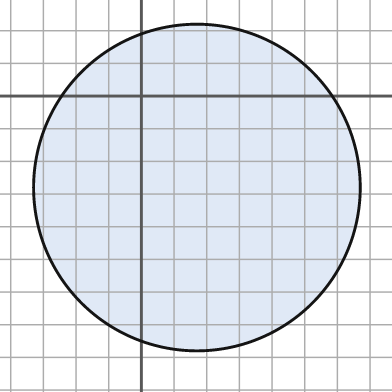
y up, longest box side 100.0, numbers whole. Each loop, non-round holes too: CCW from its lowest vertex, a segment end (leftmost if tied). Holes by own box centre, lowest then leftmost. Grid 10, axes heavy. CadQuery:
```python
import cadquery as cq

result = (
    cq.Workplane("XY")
    .moveTo(17.0, -28.0)
    .circle(50.0)
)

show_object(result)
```